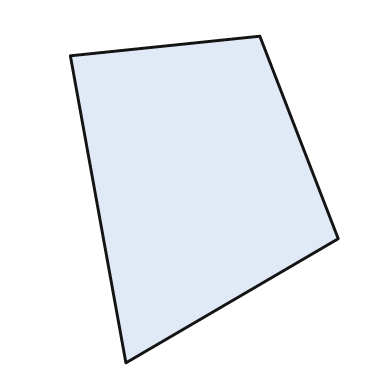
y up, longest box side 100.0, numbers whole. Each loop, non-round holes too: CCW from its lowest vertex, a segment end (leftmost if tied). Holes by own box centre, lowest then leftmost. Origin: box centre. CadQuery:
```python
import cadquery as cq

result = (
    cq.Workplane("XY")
    .moveTo(-24.0, -50.0)
    .lineTo(41.0, -12.0)
    .lineTo(17.0, 50.0)
    .lineTo(-41.0, 44.0)
    .close()
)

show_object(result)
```